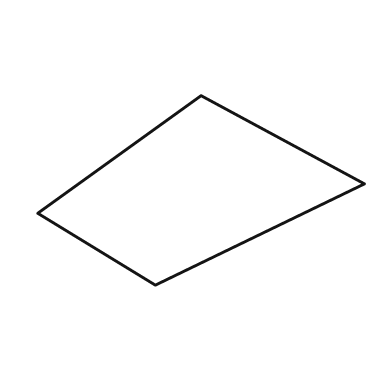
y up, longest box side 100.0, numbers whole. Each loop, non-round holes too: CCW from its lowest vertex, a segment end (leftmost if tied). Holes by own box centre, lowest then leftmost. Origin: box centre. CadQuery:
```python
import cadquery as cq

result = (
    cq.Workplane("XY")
    .moveTo(-14.0, -29.0)
    .lineTo(50.0, 2.0)
    .lineTo(0.0, 29.0)
    .lineTo(-50.0, -7.0)
    .close()
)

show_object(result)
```